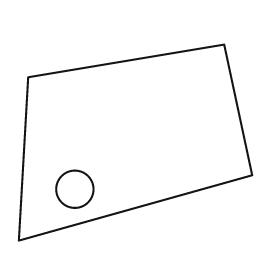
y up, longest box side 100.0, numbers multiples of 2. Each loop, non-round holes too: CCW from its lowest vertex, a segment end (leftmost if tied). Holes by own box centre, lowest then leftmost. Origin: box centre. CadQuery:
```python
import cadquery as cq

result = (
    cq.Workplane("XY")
    .moveTo(-50.0, -42.0)
    .lineTo(50.0, -14.0)
    .lineTo(38.0, 42.0)
    .lineTo(-46.0, 28.0)
    .close()
    .moveTo(-26.0, -20.0)
    .circle(8.0)
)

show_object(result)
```